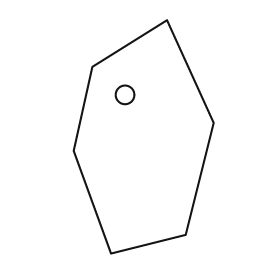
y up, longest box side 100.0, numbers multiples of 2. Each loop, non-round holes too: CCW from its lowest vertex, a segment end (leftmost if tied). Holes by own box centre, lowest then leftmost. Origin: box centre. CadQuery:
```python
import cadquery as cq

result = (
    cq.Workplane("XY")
    .moveTo(-14.0, -50.0)
    .lineTo(18.0, -42.0)
    .lineTo(30.0, 6.0)
    .lineTo(10.0, 50.0)
    .lineTo(-22.0, 30.0)
    .lineTo(-30.0, -6.0)
    .close()
    .moveTo(-8.0, 18.0)
    .circle(4.0)
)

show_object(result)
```